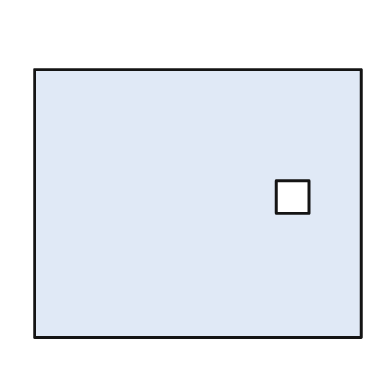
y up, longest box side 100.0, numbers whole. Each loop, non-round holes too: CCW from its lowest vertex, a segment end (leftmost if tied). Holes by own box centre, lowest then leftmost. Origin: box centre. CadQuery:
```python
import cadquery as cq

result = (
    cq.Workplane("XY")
    .moveTo(-50.0, -41.0)
    .lineTo(50.0, -41.0)
    .lineTo(50.0, 41.0)
    .lineTo(-50.0, 41.0)
    .close()
    .moveTo(24.0, -3.0)
    .lineTo(34.0, -3.0)
    .lineTo(34.0, 7.0)
    .lineTo(24.0, 7.0)
    .close()
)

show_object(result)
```